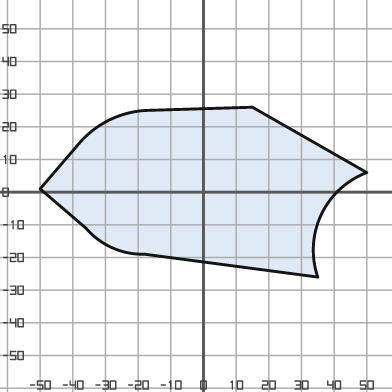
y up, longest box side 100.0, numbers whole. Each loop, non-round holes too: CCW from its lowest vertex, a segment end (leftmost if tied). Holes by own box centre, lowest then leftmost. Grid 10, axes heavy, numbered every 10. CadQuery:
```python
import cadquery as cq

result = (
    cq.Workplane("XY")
    .moveTo(35.0, -26.0)
    .threePointArc((36.0, -7.0), (50.0, 6.0))
    .lineTo(15.0, 26.0)
    .lineTo(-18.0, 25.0)
    .threePointArc((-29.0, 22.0), (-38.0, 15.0))
    .lineTo(-50.0, 1.0)
    .lineTo(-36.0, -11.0)
    .threePointArc((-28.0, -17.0), (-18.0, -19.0))
    .close()
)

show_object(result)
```